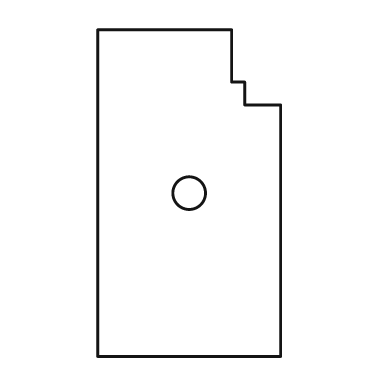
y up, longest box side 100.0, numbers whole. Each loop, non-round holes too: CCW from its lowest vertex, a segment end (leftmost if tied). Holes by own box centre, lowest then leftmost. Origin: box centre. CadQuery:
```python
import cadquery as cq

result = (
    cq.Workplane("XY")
    .moveTo(-28.0, -50.0)
    .lineTo(28.0, -50.0)
    .lineTo(28.0, 27.0)
    .lineTo(17.0, 27.0)
    .lineTo(17.0, 34.0)
    .lineTo(13.0, 34.0)
    .lineTo(13.0, 50.0)
    .lineTo(-28.0, 50.0)
    .close()
    .moveTo(0.0, 0.0)
    .circle(5.0)
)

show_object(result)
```